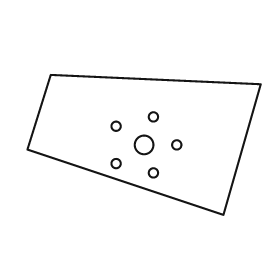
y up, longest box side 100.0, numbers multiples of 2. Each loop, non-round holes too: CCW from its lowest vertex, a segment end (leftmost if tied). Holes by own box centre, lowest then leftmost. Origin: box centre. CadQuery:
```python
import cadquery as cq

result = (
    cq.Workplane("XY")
    .moveTo(34.0, -30.0)
    .lineTo(50.0, 26.0)
    .lineTo(-40.0, 30.0)
    .lineTo(-50.0, -2.0)
    .close()
    .moveTo(4.0, -12.0)
    .circle(2.0)
    .moveTo(-12.0, -8.0)
    .circle(2.0)
    .moveTo(0.0, 0.0)
    .circle(4.0)
    .moveTo(14.0, 0.0)
    .circle(2.0)
    .moveTo(-12.0, 8.0)
    .circle(2.0)
    .moveTo(4.0, 12.0)
    .circle(2.0)
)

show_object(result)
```